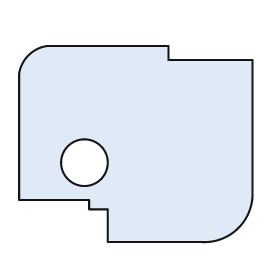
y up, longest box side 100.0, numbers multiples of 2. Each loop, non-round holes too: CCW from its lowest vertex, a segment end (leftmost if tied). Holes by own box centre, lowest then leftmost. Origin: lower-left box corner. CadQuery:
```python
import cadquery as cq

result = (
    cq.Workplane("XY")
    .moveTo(38.0, 0.0)
    .lineTo(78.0, 0.0)
    .threePointArc((94.0, 6.0), (100.0, 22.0))
    .lineTo(100.0, 78.0)
    .lineTo(64.0, 78.0)
    .lineTo(64.0, 84.0)
    .lineTo(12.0, 84.0)
    .threePointArc((4.0, 80.0), (0.0, 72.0))
    .lineTo(0.0, 18.0)
    .lineTo(30.0, 18.0)
    .lineTo(30.0, 14.0)
    .lineTo(38.0, 14.0)
    .close()
    .moveTo(28.0, 34.0)
    .circle(10.0)
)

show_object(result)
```